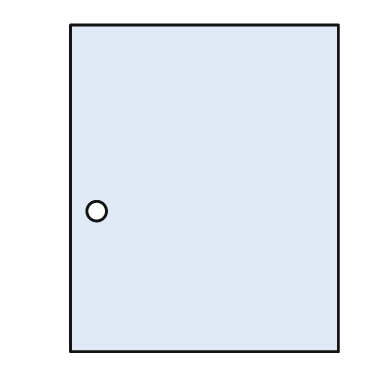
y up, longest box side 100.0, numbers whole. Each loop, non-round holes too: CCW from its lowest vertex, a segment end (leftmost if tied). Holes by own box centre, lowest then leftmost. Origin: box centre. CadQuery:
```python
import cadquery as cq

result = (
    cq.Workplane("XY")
    .moveTo(-41.0, -50.0)
    .lineTo(41.0, -50.0)
    .lineTo(41.0, 50.0)
    .lineTo(-41.0, 50.0)
    .close()
    .moveTo(-33.0, -7.0)
    .circle(3.0)
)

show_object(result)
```